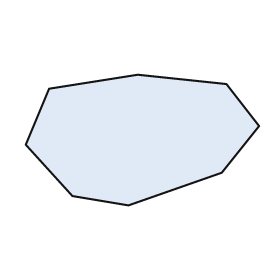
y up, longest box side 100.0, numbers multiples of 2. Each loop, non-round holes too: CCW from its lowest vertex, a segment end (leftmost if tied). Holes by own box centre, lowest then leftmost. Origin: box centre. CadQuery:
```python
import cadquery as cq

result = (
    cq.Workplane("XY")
    .moveTo(-6.0, -28.0)
    .lineTo(34.0, -14.0)
    .lineTo(50.0, 6.0)
    .lineTo(36.0, 24.0)
    .lineTo(-2.0, 28.0)
    .lineTo(-40.0, 22.0)
    .lineTo(-50.0, -2.0)
    .lineTo(-30.0, -24.0)
    .close()
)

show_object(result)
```